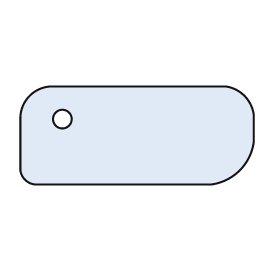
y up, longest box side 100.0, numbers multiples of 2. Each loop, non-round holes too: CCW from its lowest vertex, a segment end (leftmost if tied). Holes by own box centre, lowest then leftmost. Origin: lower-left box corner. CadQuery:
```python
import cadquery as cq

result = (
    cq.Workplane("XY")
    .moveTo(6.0, 0.0)
    .lineTo(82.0, 0.0)
    .threePointArc((94.0, 6.0), (100.0, 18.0))
    .lineTo(100.0, 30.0)
    .threePointArc((96.0, 38.0), (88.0, 42.0))
    .lineTo(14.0, 42.0)
    .threePointArc((4.0, 38.0), (0.0, 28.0))
    .lineTo(0.0, 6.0)
    .threePointArc((2.0, 2.0), (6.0, 0.0))
    .close()
    .moveTo(18.0, 28.0)
    .circle(4.0)
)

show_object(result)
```